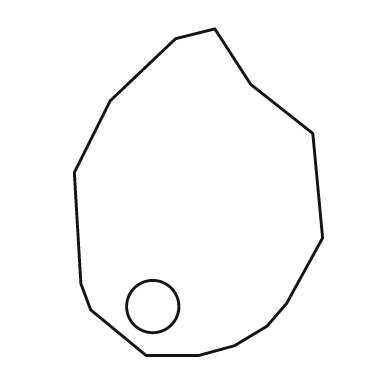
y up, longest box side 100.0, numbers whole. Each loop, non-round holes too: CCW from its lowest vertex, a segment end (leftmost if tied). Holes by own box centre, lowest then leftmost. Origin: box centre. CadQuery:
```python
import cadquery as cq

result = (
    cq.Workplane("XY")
    .moveTo(-16.0, -50.0)
    .lineTo(0.0, -50.0)
    .lineTo(11.0, -47.0)
    .lineTo(21.0, -41.0)
    .lineTo(27.0, -34.0)
    .lineTo(38.0, -14.0)
    .lineTo(35.0, 18.0)
    .lineTo(16.0, 33.0)
    .lineTo(5.0, 50.0)
    .lineTo(-7.0, 47.0)
    .lineTo(-27.0, 28.0)
    .lineTo(-38.0, 6.0)
    .lineTo(-36.0, -28.0)
    .lineTo(-33.0, -36.0)
    .close()
    .moveTo(-14.0, -35.0)
    .circle(8.0)
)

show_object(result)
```